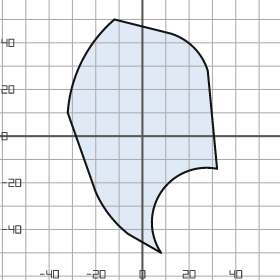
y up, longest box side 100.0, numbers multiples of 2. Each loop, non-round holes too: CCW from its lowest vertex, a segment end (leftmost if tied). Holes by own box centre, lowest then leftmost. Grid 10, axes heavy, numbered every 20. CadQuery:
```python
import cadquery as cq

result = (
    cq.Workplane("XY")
    .moveTo(8.0, -50.0)
    .threePointArc((8.0, -24.0), (32.0, -14.0))
    .lineTo(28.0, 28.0)
    .threePointArc((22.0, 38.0), (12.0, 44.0))
    .lineTo(-12.0, 50.0)
    .threePointArc((-26.0, 32.0), (-32.0, 10.0))
    .lineTo(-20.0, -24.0)
    .threePointArc((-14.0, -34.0), (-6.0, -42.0))
    .close()
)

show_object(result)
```